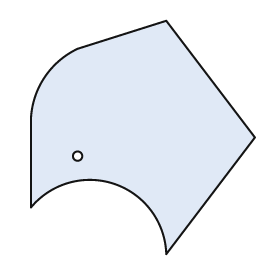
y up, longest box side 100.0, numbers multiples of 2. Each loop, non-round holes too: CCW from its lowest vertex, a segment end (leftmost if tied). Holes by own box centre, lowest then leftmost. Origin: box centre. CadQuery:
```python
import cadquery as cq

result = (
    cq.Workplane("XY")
    .moveTo(10.0, -50.0)
    .lineTo(48.0, 0.0)
    .lineTo(10.0, 50.0)
    .lineTo(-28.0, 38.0)
    .threePointArc((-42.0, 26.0), (-48.0, 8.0))
    .lineTo(-48.0, -30.0)
    .threePointArc((-12.0, -20.0), (10.0, -50.0))
    .close()
    .moveTo(-28.0, -8.0)
    .circle(2.0)
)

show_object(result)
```